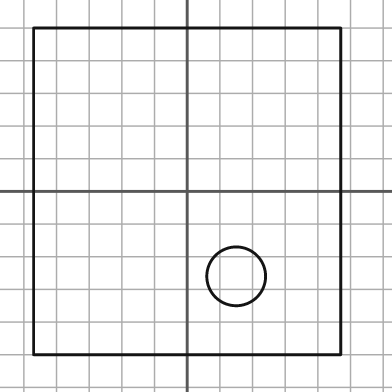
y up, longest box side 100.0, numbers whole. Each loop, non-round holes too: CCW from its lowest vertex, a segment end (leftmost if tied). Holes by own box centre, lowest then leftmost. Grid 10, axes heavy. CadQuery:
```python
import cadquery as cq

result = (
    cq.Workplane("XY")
    .moveTo(-47.0, -50.0)
    .lineTo(47.0, -50.0)
    .lineTo(47.0, 50.0)
    .lineTo(-47.0, 50.0)
    .close()
    .moveTo(15.0, -26.0)
    .circle(9.0)
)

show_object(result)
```